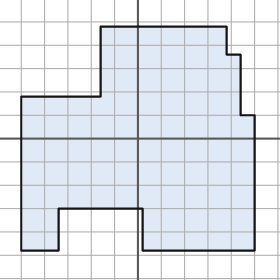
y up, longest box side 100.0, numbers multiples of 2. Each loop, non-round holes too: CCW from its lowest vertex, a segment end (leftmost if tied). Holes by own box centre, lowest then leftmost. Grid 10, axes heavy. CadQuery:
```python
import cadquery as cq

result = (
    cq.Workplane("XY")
    .moveTo(-50.0, -48.0)
    .lineTo(-34.0, -48.0)
    .lineTo(-34.0, -30.0)
    .lineTo(2.0, -30.0)
    .lineTo(2.0, -48.0)
    .lineTo(50.0, -48.0)
    .lineTo(50.0, 10.0)
    .lineTo(44.0, 10.0)
    .lineTo(44.0, 36.0)
    .lineTo(38.0, 36.0)
    .lineTo(38.0, 48.0)
    .lineTo(-16.0, 48.0)
    .lineTo(-16.0, 18.0)
    .lineTo(-50.0, 18.0)
    .close()
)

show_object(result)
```